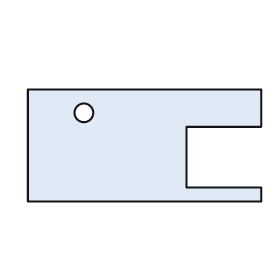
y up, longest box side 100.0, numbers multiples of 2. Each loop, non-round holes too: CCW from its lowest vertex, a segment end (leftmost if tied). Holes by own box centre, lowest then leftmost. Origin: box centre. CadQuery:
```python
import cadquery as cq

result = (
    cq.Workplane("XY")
    .moveTo(-50.0, -24.0)
    .lineTo(50.0, -24.0)
    .lineTo(50.0, -18.0)
    .lineTo(18.0, -18.0)
    .lineTo(18.0, 8.0)
    .lineTo(50.0, 8.0)
    .lineTo(50.0, 24.0)
    .lineTo(-50.0, 24.0)
    .close()
    .moveTo(-26.0, 14.0)
    .circle(4.0)
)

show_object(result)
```